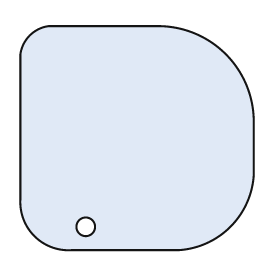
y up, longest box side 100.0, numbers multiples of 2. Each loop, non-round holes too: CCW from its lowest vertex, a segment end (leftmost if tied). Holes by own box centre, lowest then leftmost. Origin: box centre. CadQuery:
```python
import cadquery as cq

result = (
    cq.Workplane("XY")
    .moveTo(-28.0, -48.0)
    .lineTo(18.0, -48.0)
    .threePointArc((40.0, -38.0), (50.0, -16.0))
    .lineTo(50.0, 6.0)
    .threePointArc((38.0, 36.0), (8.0, 48.0))
    .lineTo(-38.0, 48.0)
    .threePointArc((-46.0, 44.0), (-50.0, 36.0))
    .lineTo(-50.0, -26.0)
    .threePointArc((-44.0, -42.0), (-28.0, -48.0))
    .close()
    .moveTo(-22.0, -38.0)
    .circle(4.0)
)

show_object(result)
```